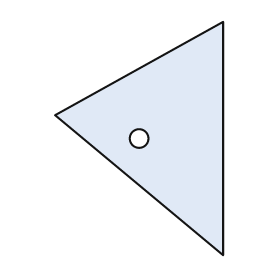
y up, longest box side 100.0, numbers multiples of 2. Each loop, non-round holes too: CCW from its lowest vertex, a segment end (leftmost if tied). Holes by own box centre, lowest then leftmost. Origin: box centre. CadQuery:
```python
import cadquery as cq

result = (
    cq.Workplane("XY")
    .moveTo(36.0, -50.0)
    .lineTo(36.0, 50.0)
    .lineTo(-36.0, 10.0)
    .close()
    .moveTo(0.0, 0.0)
    .circle(4.0)
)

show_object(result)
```